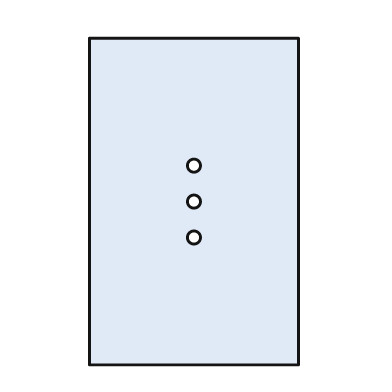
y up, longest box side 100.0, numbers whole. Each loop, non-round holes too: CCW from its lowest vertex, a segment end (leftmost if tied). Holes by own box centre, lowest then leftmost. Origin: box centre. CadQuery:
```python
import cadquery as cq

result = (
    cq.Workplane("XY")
    .moveTo(-32.0, -50.0)
    .lineTo(32.0, -50.0)
    .lineTo(32.0, 50.0)
    .lineTo(-32.0, 50.0)
    .close()
    .moveTo(0.0, -11.0)
    .circle(2.0)
    .moveTo(0.0, 0.0)
    .circle(2.0)
    .moveTo(0.0, 11.0)
    .circle(2.0)
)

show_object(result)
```